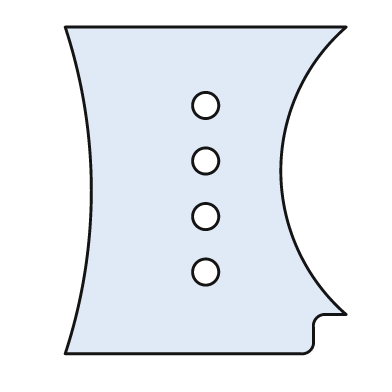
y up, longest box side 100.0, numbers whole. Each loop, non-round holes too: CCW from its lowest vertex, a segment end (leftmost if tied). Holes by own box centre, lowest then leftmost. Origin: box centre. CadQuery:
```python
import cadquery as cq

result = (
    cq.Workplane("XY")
    .moveTo(-43.0, -50.0)
    .lineTo(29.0, -50.0)
    .threePointArc((32.0, -49.0), (33.0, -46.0))
    .lineTo(33.0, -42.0)
    .threePointArc((34.0, -39.0), (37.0, -38.0))
    .lineTo(43.0, -38.0)
    .threePointArc((23.0, 6.0), (43.0, 50.0))
    .lineTo(-43.0, 50.0)
    .threePointArc((-35.0, 0.0), (-43.0, -50.0))
    .close()
    .moveTo(0.0, -25.0)
    .circle(4.0)
    .moveTo(0.0, -8.0)
    .circle(4.0)
    .moveTo(0.0, 9.0)
    .circle(4.0)
    .moveTo(0.0, 26.0)
    .circle(4.0)
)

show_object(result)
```